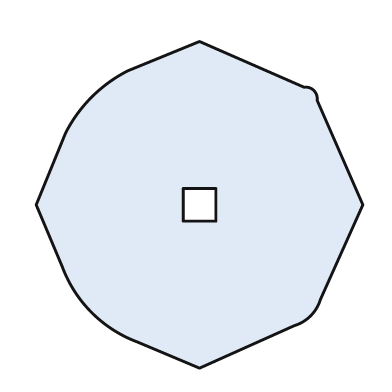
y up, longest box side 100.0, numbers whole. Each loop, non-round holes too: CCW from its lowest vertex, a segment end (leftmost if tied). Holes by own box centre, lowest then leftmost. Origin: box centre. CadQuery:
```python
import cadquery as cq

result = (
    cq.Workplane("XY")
    .moveTo(0.0, -50.0)
    .lineTo(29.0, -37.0)
    .threePointArc((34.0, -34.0), (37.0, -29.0))
    .lineTo(50.0, 0.0)
    .lineTo(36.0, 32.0)
    .threePointArc((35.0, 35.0), (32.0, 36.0))
    .lineTo(0.0, 50.0)
    .lineTo(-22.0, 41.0)
    .threePointArc((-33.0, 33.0), (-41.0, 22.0))
    .lineTo(-50.0, 0.0)
    .lineTo(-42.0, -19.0)
    .threePointArc((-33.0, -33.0), (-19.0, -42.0))
    .close()
    .moveTo(-5.0, -5.0)
    .lineTo(5.0, -5.0)
    .lineTo(5.0, 5.0)
    .lineTo(-5.0, 5.0)
    .close()
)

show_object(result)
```